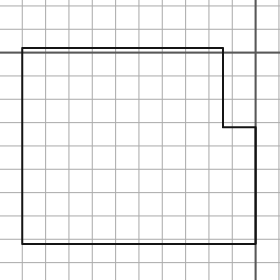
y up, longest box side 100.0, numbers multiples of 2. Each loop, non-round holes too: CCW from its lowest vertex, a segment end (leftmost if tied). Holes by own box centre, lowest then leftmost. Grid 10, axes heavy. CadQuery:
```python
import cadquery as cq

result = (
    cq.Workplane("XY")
    .moveTo(-100.0, -82.0)
    .lineTo(0.0, -82.0)
    .lineTo(0.0, -32.0)
    .lineTo(-14.0, -32.0)
    .lineTo(-14.0, 2.0)
    .lineTo(-100.0, 2.0)
    .close()
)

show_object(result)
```